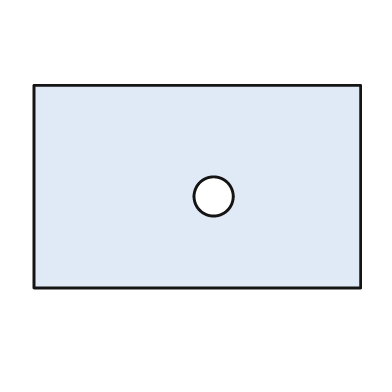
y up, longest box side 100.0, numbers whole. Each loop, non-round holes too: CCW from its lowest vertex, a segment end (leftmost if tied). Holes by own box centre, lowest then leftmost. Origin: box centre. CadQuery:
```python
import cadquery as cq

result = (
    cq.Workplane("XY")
    .moveTo(-50.0, -31.0)
    .lineTo(50.0, -31.0)
    .lineTo(50.0, 31.0)
    .lineTo(-50.0, 31.0)
    .close()
    .moveTo(5.0, -3.0)
    .circle(6.0)
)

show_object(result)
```